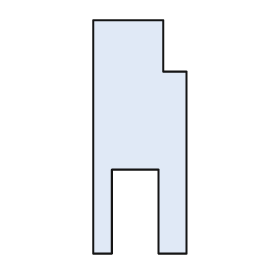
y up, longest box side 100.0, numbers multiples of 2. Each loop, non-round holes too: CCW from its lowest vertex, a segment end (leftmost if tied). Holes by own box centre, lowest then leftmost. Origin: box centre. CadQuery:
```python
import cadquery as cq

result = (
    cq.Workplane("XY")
    .moveTo(-20.0, -50.0)
    .lineTo(-12.0, -50.0)
    .lineTo(-12.0, -14.0)
    .lineTo(8.0, -14.0)
    .lineTo(8.0, -50.0)
    .lineTo(20.0, -50.0)
    .lineTo(20.0, 28.0)
    .lineTo(10.0, 28.0)
    .lineTo(10.0, 50.0)
    .lineTo(-20.0, 50.0)
    .close()
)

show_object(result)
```